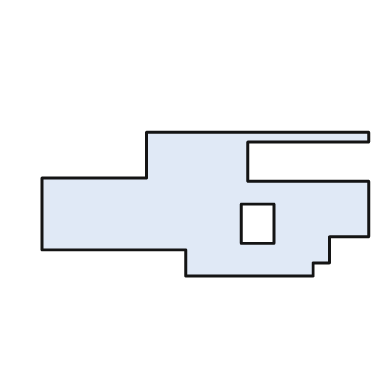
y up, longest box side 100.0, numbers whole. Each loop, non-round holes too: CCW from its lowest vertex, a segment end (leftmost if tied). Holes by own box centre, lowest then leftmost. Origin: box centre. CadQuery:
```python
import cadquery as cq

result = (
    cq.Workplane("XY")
    .moveTo(-6.0, -22.0)
    .lineTo(33.0, -22.0)
    .lineTo(33.0, -18.0)
    .lineTo(38.0, -18.0)
    .lineTo(38.0, -10.0)
    .lineTo(50.0, -10.0)
    .lineTo(50.0, 7.0)
    .lineTo(13.0, 7.0)
    .lineTo(13.0, 19.0)
    .lineTo(50.0, 19.0)
    .lineTo(50.0, 22.0)
    .lineTo(-18.0, 22.0)
    .lineTo(-18.0, 8.0)
    .lineTo(-50.0, 8.0)
    .lineTo(-50.0, -14.0)
    .lineTo(-6.0, -14.0)
    .close()
    .moveTo(11.0, -12.0)
    .lineTo(21.0, -12.0)
    .lineTo(21.0, 0.0)
    .lineTo(11.0, 0.0)
    .close()
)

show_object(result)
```